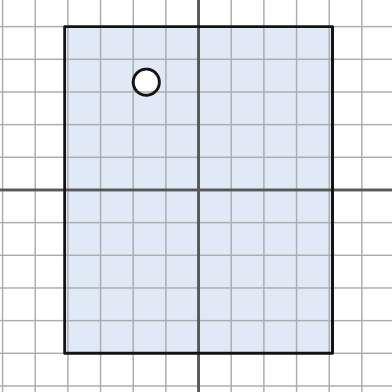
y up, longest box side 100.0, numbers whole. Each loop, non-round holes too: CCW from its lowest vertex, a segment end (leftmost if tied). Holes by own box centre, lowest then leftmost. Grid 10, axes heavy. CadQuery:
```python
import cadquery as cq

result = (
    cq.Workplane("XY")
    .moveTo(-41.0, -50.0)
    .lineTo(41.0, -50.0)
    .lineTo(41.0, 50.0)
    .lineTo(-41.0, 50.0)
    .close()
    .moveTo(-16.0, 33.0)
    .circle(4.0)
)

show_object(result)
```